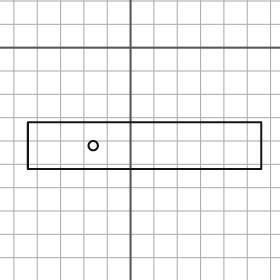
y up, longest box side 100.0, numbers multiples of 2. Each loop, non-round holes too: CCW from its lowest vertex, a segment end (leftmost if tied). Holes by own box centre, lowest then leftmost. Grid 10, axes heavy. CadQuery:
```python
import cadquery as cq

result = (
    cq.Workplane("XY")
    .moveTo(-44.0, -52.0)
    .lineTo(56.0, -52.0)
    .lineTo(56.0, -32.0)
    .lineTo(-44.0, -32.0)
    .close()
    .moveTo(-16.0, -42.0)
    .circle(2.0)
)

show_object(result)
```